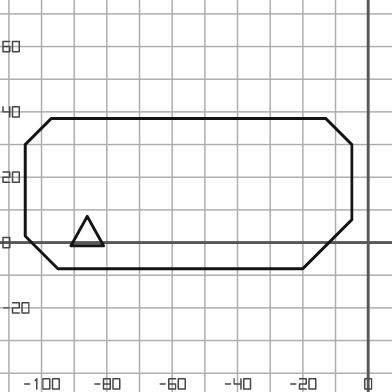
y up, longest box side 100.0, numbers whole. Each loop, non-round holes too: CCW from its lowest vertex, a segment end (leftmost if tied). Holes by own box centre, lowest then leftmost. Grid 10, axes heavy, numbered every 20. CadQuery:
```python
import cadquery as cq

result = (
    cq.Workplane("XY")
    .moveTo(-95.0, -8.0)
    .lineTo(-20.0, -8.0)
    .lineTo(-5.0, 7.0)
    .lineTo(-5.0, 30.0)
    .lineTo(-13.0, 38.0)
    .lineTo(-97.0, 38.0)
    .lineTo(-105.0, 30.0)
    .lineTo(-105.0, 2.0)
    .close()
    .moveTo(-91.0, -1.0)
    .lineTo(-81.0, -1.0)
    .lineTo(-86.0, 8.0)
    .close()
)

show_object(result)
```